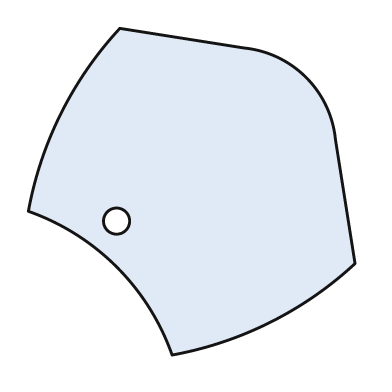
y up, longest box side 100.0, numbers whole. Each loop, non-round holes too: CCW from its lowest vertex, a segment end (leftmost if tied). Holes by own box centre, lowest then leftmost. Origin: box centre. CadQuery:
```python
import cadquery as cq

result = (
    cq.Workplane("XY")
    .moveTo(-6.0, -50.0)
    .threePointArc((24.0, -40.0), (50.0, -22.0))
    .lineTo(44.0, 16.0)
    .threePointArc((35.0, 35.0), (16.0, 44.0))
    .lineTo(-22.0, 50.0)
    .threePointArc((-40.0, 24.0), (-50.0, -6.0))
    .threePointArc((-23.0, -23.0), (-6.0, -50.0))
    .close()
    .moveTo(-23.0, -9.0)
    .circle(4.0)
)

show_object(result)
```